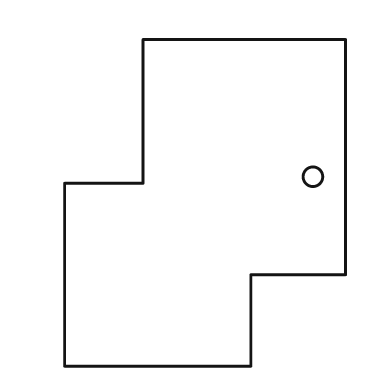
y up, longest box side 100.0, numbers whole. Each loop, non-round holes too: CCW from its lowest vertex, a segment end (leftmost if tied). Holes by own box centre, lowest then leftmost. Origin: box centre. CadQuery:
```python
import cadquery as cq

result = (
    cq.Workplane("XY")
    .moveTo(-43.0, -50.0)
    .lineTo(14.0, -50.0)
    .lineTo(14.0, -22.0)
    .lineTo(43.0, -22.0)
    .lineTo(43.0, 50.0)
    .lineTo(-19.0, 50.0)
    .lineTo(-19.0, 6.0)
    .lineTo(-43.0, 6.0)
    .close()
    .moveTo(33.0, 8.0)
    .circle(3.0)
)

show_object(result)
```